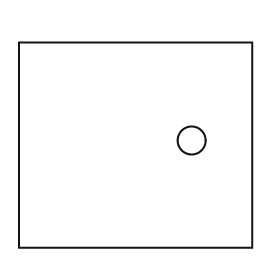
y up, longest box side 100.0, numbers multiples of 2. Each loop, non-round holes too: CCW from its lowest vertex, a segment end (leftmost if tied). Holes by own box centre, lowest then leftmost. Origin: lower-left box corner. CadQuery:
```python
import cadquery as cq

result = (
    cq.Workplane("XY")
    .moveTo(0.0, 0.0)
    .lineTo(100.0, 0.0)
    .lineTo(100.0, 88.0)
    .lineTo(0.0, 88.0)
    .close()
    .moveTo(74.0, 46.0)
    .circle(6.0)
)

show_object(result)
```